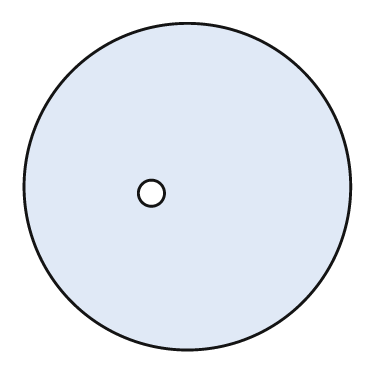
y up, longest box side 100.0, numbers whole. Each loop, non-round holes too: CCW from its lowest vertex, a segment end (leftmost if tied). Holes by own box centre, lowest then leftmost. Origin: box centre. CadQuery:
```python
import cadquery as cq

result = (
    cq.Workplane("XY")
    .moveTo(0.0, 0.0)
    .circle(50.0)
    .moveTo(-11.0, -2.0)
    .circle(4.0)
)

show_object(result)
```